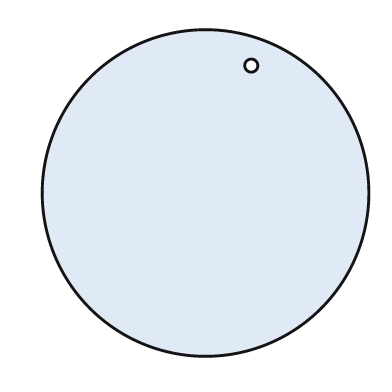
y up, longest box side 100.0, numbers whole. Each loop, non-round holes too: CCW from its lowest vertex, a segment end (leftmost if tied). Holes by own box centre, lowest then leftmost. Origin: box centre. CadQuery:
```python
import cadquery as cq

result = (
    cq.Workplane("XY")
    .moveTo(0.0, 0.0)
    .circle(50.0)
    .moveTo(14.0, 39.0)
    .circle(2.0)
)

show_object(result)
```